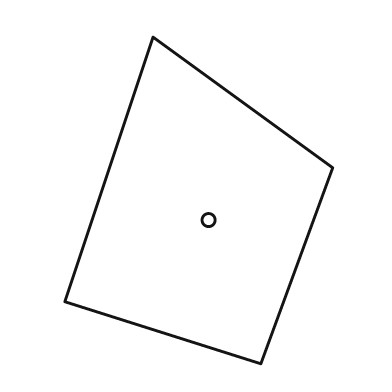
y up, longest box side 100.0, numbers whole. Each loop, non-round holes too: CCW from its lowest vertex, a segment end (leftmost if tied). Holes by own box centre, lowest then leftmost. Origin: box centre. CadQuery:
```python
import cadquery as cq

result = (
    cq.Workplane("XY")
    .moveTo(19.0, -50.0)
    .lineTo(41.0, 10.0)
    .lineTo(-14.0, 50.0)
    .lineTo(-41.0, -31.0)
    .close()
    .moveTo(3.0, -6.0)
    .circle(2.0)
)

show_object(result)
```